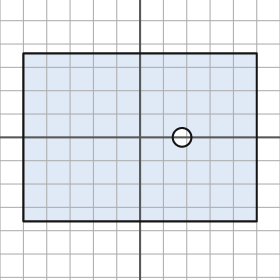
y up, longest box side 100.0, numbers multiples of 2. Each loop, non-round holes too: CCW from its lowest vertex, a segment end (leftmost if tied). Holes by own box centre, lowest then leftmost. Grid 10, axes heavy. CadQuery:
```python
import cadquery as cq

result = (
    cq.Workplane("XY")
    .moveTo(-50.0, -36.0)
    .lineTo(50.0, -36.0)
    .lineTo(50.0, 36.0)
    .lineTo(-50.0, 36.0)
    .close()
    .moveTo(18.0, 0.0)
    .circle(4.0)
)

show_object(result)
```